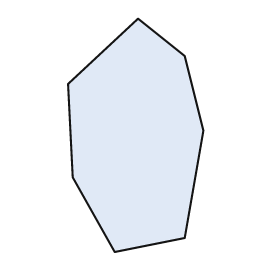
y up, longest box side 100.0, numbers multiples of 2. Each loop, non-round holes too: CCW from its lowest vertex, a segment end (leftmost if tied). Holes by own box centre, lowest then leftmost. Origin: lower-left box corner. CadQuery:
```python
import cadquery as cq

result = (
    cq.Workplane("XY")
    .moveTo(20.0, 0.0)
    .lineTo(50.0, 6.0)
    .lineTo(58.0, 52.0)
    .lineTo(50.0, 84.0)
    .lineTo(30.0, 100.0)
    .lineTo(0.0, 72.0)
    .lineTo(2.0, 32.0)
    .close()
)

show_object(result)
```